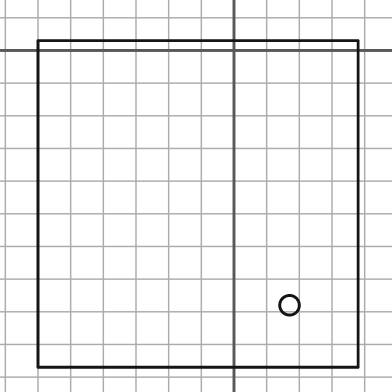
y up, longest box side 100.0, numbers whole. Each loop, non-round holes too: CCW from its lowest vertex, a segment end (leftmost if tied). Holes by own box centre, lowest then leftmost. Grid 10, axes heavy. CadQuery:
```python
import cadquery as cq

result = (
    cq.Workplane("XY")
    .moveTo(-60.0, -97.0)
    .lineTo(38.0, -97.0)
    .lineTo(38.0, 3.0)
    .lineTo(-60.0, 3.0)
    .close()
    .moveTo(17.0, -78.0)
    .circle(3.0)
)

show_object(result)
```